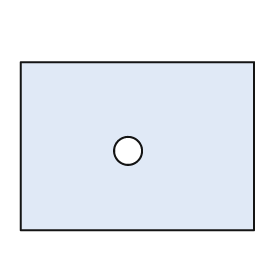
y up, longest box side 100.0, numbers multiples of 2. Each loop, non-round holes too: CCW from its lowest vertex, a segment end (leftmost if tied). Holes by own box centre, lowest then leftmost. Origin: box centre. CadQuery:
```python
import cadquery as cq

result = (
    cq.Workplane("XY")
    .moveTo(-50.0, -36.0)
    .lineTo(50.0, -36.0)
    .lineTo(50.0, 36.0)
    .lineTo(-50.0, 36.0)
    .close()
    .moveTo(-4.0, -2.0)
    .circle(6.0)
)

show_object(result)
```